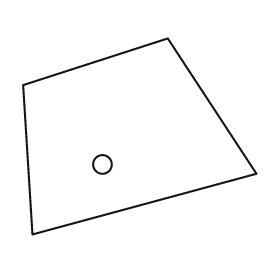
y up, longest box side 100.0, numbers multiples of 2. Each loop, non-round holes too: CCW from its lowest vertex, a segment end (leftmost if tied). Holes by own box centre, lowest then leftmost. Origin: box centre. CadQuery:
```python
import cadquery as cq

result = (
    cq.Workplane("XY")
    .moveTo(-46.0, -42.0)
    .lineTo(50.0, -16.0)
    .lineTo(12.0, 42.0)
    .lineTo(-50.0, 22.0)
    .close()
    .moveTo(-16.0, -12.0)
    .circle(4.0)
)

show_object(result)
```